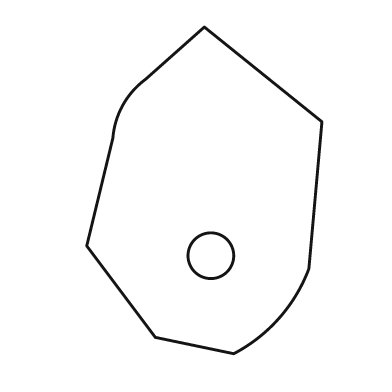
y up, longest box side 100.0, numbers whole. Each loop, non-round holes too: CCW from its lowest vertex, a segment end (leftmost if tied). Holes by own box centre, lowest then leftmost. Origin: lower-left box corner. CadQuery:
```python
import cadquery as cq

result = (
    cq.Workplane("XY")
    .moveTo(45.0, 0.0)
    .threePointArc((59.0, 11.0), (68.0, 26.0))
    .lineTo(72.0, 71.0)
    .lineTo(36.0, 100.0)
    .lineTo(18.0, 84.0)
    .threePointArc((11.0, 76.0), (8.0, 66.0))
    .lineTo(0.0, 33.0)
    .lineTo(21.0, 5.0)
    .close()
    .moveTo(38.0, 30.0)
    .circle(7.0)
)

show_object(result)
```